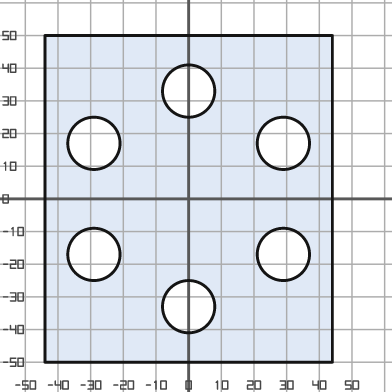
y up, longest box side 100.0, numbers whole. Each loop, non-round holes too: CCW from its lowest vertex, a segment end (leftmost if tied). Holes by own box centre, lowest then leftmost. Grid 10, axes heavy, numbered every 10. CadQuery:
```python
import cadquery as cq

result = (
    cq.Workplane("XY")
    .moveTo(-44.0, -50.0)
    .lineTo(44.0, -50.0)
    .lineTo(44.0, 50.0)
    .lineTo(-44.0, 50.0)
    .close()
    .moveTo(0.0, -33.0)
    .circle(8.0)
    .moveTo(-29.0, -17.0)
    .circle(8.0)
    .moveTo(29.0, -17.0)
    .circle(8.0)
    .moveTo(-29.0, 17.0)
    .circle(8.0)
    .moveTo(29.0, 17.0)
    .circle(8.0)
    .moveTo(0.0, 33.0)
    .circle(8.0)
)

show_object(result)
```